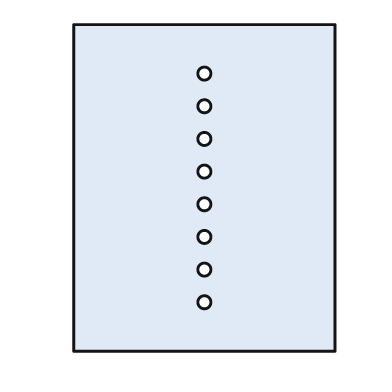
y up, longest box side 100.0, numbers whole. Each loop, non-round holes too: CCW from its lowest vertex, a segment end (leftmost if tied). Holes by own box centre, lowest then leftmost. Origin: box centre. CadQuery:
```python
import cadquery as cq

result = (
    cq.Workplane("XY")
    .moveTo(-40.0, -50.0)
    .lineTo(40.0, -50.0)
    .lineTo(40.0, 50.0)
    .lineTo(-40.0, 50.0)
    .close()
    .moveTo(0.0, -35.0)
    .circle(2.0)
    .moveTo(0.0, -25.0)
    .circle(2.0)
    .moveTo(0.0, -15.0)
    .circle(2.0)
    .moveTo(0.0, -5.0)
    .circle(2.0)
    .moveTo(0.0, 5.0)
    .circle(2.0)
    .moveTo(0.0, 15.0)
    .circle(2.0)
    .moveTo(0.0, 25.0)
    .circle(2.0)
    .moveTo(0.0, 35.0)
    .circle(2.0)
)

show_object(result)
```